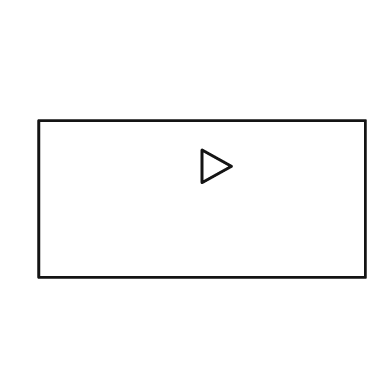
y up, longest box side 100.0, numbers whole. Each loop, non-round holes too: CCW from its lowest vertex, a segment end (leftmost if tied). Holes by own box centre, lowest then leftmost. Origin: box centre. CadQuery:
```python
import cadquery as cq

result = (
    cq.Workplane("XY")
    .moveTo(-50.0, -24.0)
    .lineTo(50.0, -24.0)
    .lineTo(50.0, 24.0)
    .lineTo(-50.0, 24.0)
    .close()
    .moveTo(0.0, 5.0)
    .lineTo(9.0, 10.0)
    .lineTo(0.0, 15.0)
    .close()
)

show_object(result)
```